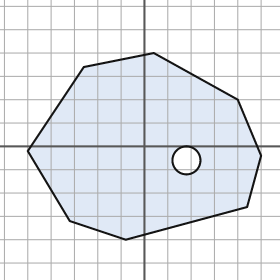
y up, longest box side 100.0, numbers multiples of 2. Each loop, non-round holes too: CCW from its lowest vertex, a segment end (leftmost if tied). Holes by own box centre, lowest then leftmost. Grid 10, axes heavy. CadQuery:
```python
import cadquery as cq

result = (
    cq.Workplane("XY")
    .moveTo(-8.0, -40.0)
    .lineTo(44.0, -26.0)
    .lineTo(50.0, -4.0)
    .lineTo(40.0, 20.0)
    .lineTo(4.0, 40.0)
    .lineTo(-26.0, 34.0)
    .lineTo(-50.0, -2.0)
    .lineTo(-32.0, -32.0)
    .close()
    .moveTo(18.0, -6.0)
    .circle(6.0)
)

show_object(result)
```